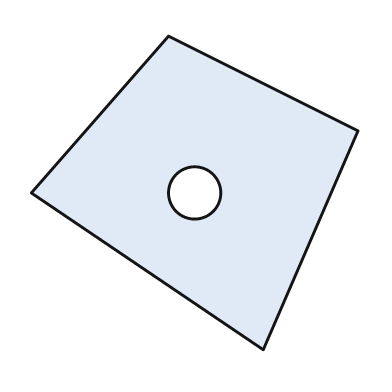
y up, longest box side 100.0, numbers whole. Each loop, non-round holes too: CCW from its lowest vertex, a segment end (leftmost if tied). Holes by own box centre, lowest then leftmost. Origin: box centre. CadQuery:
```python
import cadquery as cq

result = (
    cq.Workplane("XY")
    .moveTo(21.0, -48.0)
    .lineTo(50.0, 19.0)
    .lineTo(-8.0, 48.0)
    .lineTo(-50.0, 0.0)
    .close()
    .moveTo(0.0, 0.0)
    .circle(8.0)
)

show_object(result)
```